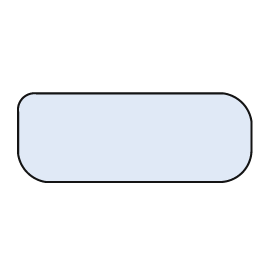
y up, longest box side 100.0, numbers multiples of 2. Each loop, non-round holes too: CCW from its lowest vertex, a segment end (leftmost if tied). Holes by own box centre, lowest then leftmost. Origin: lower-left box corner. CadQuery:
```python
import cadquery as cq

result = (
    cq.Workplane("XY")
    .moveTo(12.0, 0.0)
    .lineTo(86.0, 0.0)
    .threePointArc((96.0, 4.0), (100.0, 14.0))
    .lineTo(100.0, 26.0)
    .threePointArc((96.0, 34.0), (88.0, 38.0))
    .lineTo(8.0, 38.0)
    .threePointArc((2.0, 36.0), (0.0, 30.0))
    .lineTo(0.0, 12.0)
    .threePointArc((4.0, 4.0), (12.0, 0.0))
    .close()
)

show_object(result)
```